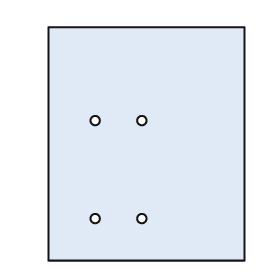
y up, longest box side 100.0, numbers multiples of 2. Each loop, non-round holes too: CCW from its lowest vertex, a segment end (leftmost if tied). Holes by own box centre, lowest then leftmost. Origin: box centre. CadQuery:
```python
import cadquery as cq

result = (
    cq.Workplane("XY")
    .moveTo(-42.0, -50.0)
    .lineTo(42.0, -50.0)
    .lineTo(42.0, 50.0)
    .lineTo(-42.0, 50.0)
    .close()
    .moveTo(-22.0, -32.0)
    .circle(2.0)
    .moveTo(-2.0, -32.0)
    .circle(2.0)
    .moveTo(-22.0, 10.0)
    .circle(2.0)
    .moveTo(-2.0, 10.0)
    .circle(2.0)
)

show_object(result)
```